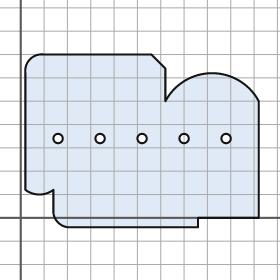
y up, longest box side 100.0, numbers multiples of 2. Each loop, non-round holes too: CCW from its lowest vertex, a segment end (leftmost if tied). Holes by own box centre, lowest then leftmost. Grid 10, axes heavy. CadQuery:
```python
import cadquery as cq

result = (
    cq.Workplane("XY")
    .moveTo(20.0, -4.0)
    .lineTo(76.0, -4.0)
    .lineTo(76.0, 0.0)
    .lineTo(102.0, 0.0)
    .lineTo(102.0, 50.0)
    .threePointArc((82.0, 62.0), (62.0, 50.0))
    .lineTo(62.0, 64.0)
    .lineTo(56.0, 70.0)
    .lineTo(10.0, 70.0)
    .threePointArc((4.0, 68.0), (2.0, 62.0))
    .lineTo(2.0, 12.0)
    .threePointArc((8.0, 10.0), (14.0, 12.0))
    .lineTo(14.0, 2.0)
    .threePointArc((16.0, -2.0), (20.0, -4.0))
    .close()
    .moveTo(16.0, 34.0)
    .circle(2.0)
    .moveTo(34.0, 34.0)
    .circle(2.0)
    .moveTo(52.0, 34.0)
    .circle(2.0)
    .moveTo(70.0, 34.0)
    .circle(2.0)
    .moveTo(88.0, 34.0)
    .circle(2.0)
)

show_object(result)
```